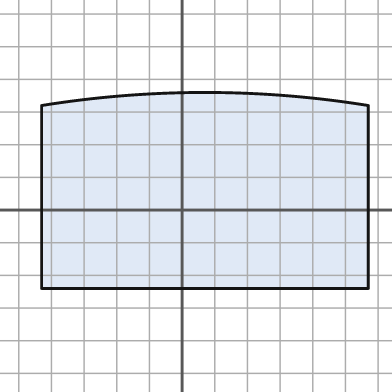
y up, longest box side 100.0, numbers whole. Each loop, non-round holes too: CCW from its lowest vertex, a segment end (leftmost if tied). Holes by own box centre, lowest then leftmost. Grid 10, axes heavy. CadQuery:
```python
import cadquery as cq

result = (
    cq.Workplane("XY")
    .moveTo(-43.0, -24.0)
    .lineTo(57.0, -24.0)
    .lineTo(57.0, 32.0)
    .threePointArc((7.0, 36.0), (-43.0, 32.0))
    .close()
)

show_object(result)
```